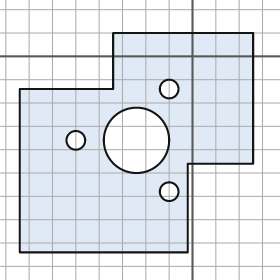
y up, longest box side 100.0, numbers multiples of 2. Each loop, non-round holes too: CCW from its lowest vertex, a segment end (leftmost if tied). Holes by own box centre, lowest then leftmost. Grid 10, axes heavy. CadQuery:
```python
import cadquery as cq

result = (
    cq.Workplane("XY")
    .moveTo(-74.0, -84.0)
    .lineTo(-2.0, -84.0)
    .lineTo(-2.0, -46.0)
    .lineTo(26.0, -46.0)
    .lineTo(26.0, 10.0)
    .lineTo(-34.0, 10.0)
    .lineTo(-34.0, -14.0)
    .lineTo(-74.0, -14.0)
    .close()
    .moveTo(-10.0, -58.0)
    .circle(4.0)
    .moveTo(-50.0, -36.0)
    .circle(4.0)
    .moveTo(-24.0, -36.0)
    .circle(14.0)
    .moveTo(-10.0, -14.0)
    .circle(4.0)
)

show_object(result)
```